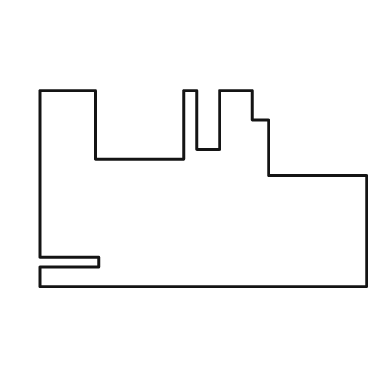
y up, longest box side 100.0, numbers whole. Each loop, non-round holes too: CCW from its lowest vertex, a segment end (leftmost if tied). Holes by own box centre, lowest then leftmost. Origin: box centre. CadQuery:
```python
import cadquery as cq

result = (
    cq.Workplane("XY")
    .moveTo(-50.0, -30.0)
    .lineTo(50.0, -30.0)
    .lineTo(50.0, 4.0)
    .lineTo(20.0, 4.0)
    .lineTo(20.0, 21.0)
    .lineTo(15.0, 21.0)
    .lineTo(15.0, 30.0)
    .lineTo(5.0, 30.0)
    .lineTo(5.0, 12.0)
    .lineTo(-2.0, 12.0)
    .lineTo(-2.0, 30.0)
    .lineTo(-6.0, 30.0)
    .lineTo(-6.0, 9.0)
    .lineTo(-33.0, 9.0)
    .lineTo(-33.0, 30.0)
    .lineTo(-50.0, 30.0)
    .lineTo(-50.0, -21.0)
    .lineTo(-32.0, -21.0)
    .lineTo(-32.0, -24.0)
    .lineTo(-50.0, -24.0)
    .close()
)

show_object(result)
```